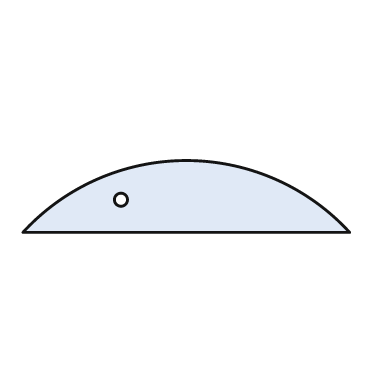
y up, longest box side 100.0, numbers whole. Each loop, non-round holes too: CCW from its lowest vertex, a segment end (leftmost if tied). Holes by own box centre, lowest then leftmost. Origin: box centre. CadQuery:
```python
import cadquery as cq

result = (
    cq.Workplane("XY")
    .moveTo(-50.0, -11.0)
    .lineTo(50.0, -11.0)
    .threePointArc((0.0, 11.0), (-50.0, -11.0))
    .close()
    .moveTo(-20.0, -1.0)
    .circle(2.0)
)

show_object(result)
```